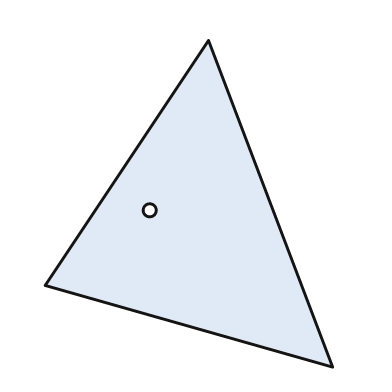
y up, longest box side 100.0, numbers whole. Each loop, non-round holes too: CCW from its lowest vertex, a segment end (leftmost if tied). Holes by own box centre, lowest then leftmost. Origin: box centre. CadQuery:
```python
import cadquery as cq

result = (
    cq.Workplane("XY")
    .moveTo(44.0, -50.0)
    .lineTo(6.0, 50.0)
    .lineTo(-44.0, -25.0)
    .close()
    .moveTo(-12.0, -2.0)
    .circle(2.0)
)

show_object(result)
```